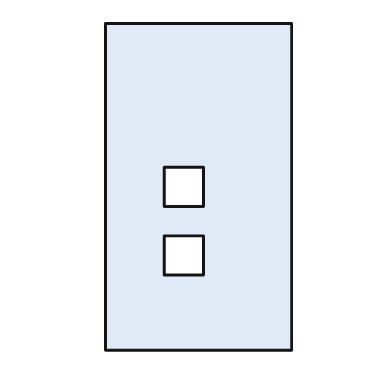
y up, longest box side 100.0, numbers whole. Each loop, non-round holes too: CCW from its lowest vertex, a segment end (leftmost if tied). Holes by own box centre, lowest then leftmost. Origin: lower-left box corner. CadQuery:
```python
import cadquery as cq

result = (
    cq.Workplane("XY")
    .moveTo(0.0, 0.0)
    .lineTo(57.0, 0.0)
    .lineTo(57.0, 100.0)
    .lineTo(0.0, 100.0)
    .close()
    .moveTo(18.0, 23.0)
    .lineTo(30.0, 23.0)
    .lineTo(30.0, 35.0)
    .lineTo(18.0, 35.0)
    .close()
    .moveTo(18.0, 44.0)
    .lineTo(30.0, 44.0)
    .lineTo(30.0, 56.0)
    .lineTo(18.0, 56.0)
    .close()
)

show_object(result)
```